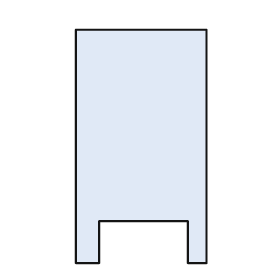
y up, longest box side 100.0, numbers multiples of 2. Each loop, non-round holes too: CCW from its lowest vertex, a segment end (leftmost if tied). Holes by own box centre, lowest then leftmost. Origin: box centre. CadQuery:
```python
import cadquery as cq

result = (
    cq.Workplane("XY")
    .moveTo(-28.0, -50.0)
    .lineTo(-18.0, -50.0)
    .lineTo(-18.0, -32.0)
    .lineTo(20.0, -32.0)
    .lineTo(20.0, -50.0)
    .lineTo(28.0, -50.0)
    .lineTo(28.0, 50.0)
    .lineTo(-28.0, 50.0)
    .close()
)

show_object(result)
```